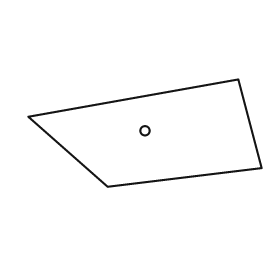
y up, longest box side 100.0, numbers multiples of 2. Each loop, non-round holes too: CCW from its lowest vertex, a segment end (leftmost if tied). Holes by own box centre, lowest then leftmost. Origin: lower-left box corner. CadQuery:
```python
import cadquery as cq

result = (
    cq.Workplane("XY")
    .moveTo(34.0, 0.0)
    .lineTo(100.0, 8.0)
    .lineTo(90.0, 46.0)
    .lineTo(0.0, 30.0)
    .close()
    .moveTo(50.0, 24.0)
    .circle(2.0)
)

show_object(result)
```